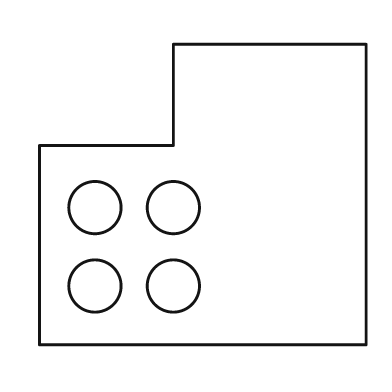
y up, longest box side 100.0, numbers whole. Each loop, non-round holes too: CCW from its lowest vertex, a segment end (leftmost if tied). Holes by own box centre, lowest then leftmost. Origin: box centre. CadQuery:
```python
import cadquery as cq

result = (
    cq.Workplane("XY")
    .moveTo(-50.0, -46.0)
    .lineTo(50.0, -46.0)
    .lineTo(50.0, 46.0)
    .lineTo(-9.0, 46.0)
    .lineTo(-9.0, 15.0)
    .lineTo(-50.0, 15.0)
    .close()
    .moveTo(-33.0, -28.0)
    .circle(8.0)
    .moveTo(-9.0, -28.0)
    .circle(8.0)
    .moveTo(-33.0, -4.0)
    .circle(8.0)
    .moveTo(-9.0, -4.0)
    .circle(8.0)
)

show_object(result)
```